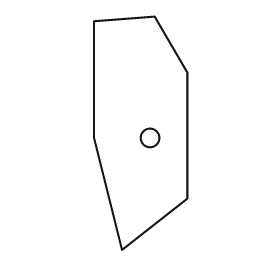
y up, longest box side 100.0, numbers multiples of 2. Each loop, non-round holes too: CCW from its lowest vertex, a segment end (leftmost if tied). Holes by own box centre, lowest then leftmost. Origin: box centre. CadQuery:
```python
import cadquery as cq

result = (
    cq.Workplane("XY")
    .moveTo(-8.0, -50.0)
    .lineTo(20.0, -28.0)
    .lineTo(20.0, 26.0)
    .lineTo(6.0, 50.0)
    .lineTo(-20.0, 48.0)
    .lineTo(-20.0, -2.0)
    .close()
    .moveTo(4.0, -2.0)
    .circle(4.0)
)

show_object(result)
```